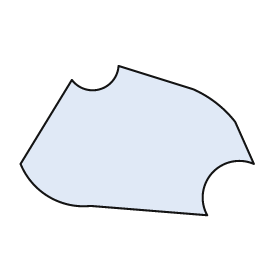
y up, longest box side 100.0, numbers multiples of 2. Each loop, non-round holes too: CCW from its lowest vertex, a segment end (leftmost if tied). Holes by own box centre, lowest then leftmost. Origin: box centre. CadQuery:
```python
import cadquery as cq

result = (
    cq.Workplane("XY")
    .moveTo(30.0, -32.0)
    .threePointArc((32.0, -14.0), (50.0, -10.0))
    .lineTo(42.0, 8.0)
    .threePointArc((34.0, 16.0), (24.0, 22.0))
    .lineTo(-8.0, 32.0)
    .threePointArc((-16.0, 22.0), (-28.0, 26.0))
    .lineTo(-50.0, -10.0)
    .threePointArc((-38.0, -24.0), (-20.0, -28.0))
    .close()
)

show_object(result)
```